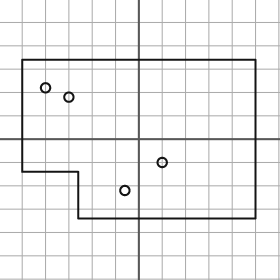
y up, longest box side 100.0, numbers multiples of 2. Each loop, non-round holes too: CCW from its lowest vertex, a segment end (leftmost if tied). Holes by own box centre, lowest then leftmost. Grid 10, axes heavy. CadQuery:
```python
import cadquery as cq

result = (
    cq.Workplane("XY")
    .moveTo(-26.0, -34.0)
    .lineTo(50.0, -34.0)
    .lineTo(50.0, 34.0)
    .lineTo(-50.0, 34.0)
    .lineTo(-50.0, -14.0)
    .lineTo(-26.0, -14.0)
    .close()
    .moveTo(-6.0, -22.0)
    .circle(2.0)
    .moveTo(10.0, -10.0)
    .circle(2.0)
    .moveTo(-30.0, 18.0)
    .circle(2.0)
    .moveTo(-40.0, 22.0)
    .circle(2.0)
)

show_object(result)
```